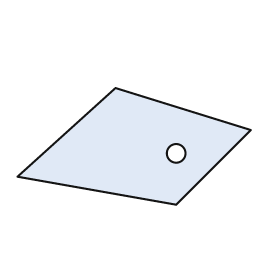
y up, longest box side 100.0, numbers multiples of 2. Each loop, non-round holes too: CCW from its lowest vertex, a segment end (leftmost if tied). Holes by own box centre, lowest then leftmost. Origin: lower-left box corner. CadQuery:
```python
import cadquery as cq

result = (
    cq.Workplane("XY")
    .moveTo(68.0, 0.0)
    .lineTo(100.0, 32.0)
    .lineTo(42.0, 50.0)
    .lineTo(0.0, 12.0)
    .close()
    .moveTo(68.0, 22.0)
    .circle(4.0)
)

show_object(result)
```